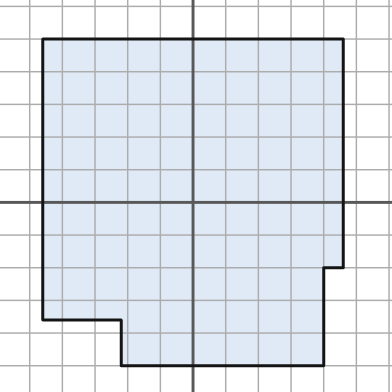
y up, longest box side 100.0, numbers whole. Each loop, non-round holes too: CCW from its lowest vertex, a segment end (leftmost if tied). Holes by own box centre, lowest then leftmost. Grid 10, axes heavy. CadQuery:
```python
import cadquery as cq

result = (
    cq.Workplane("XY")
    .moveTo(-22.0, -50.0)
    .lineTo(40.0, -50.0)
    .lineTo(40.0, -20.0)
    .lineTo(46.0, -20.0)
    .lineTo(46.0, 50.0)
    .lineTo(-46.0, 50.0)
    .lineTo(-46.0, -36.0)
    .lineTo(-22.0, -36.0)
    .close()
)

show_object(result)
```